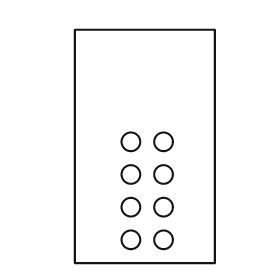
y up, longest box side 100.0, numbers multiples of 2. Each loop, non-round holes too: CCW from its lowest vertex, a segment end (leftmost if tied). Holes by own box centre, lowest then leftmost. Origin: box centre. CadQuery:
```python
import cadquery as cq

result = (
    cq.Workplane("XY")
    .moveTo(-30.0, -50.0)
    .lineTo(30.0, -50.0)
    .lineTo(30.0, 50.0)
    .lineTo(-30.0, 50.0)
    .close()
    .moveTo(-6.0, -40.0)
    .circle(4.0)
    .moveTo(8.0, -40.0)
    .circle(4.0)
    .moveTo(-6.0, -26.0)
    .circle(4.0)
    .moveTo(8.0, -26.0)
    .circle(4.0)
    .moveTo(-6.0, -12.0)
    .circle(4.0)
    .moveTo(8.0, -12.0)
    .circle(4.0)
    .moveTo(-6.0, 2.0)
    .circle(4.0)
    .moveTo(8.0, 2.0)
    .circle(4.0)
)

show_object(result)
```